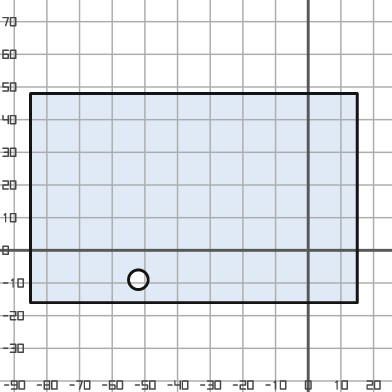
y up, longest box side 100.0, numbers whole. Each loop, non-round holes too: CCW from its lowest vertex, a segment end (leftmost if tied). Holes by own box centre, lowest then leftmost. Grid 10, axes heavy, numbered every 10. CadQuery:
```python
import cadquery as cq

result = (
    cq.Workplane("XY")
    .moveTo(-85.0, -16.0)
    .lineTo(15.0, -16.0)
    .lineTo(15.0, 48.0)
    .lineTo(-85.0, 48.0)
    .close()
    .moveTo(-52.0, -9.0)
    .circle(3.0)
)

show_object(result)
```